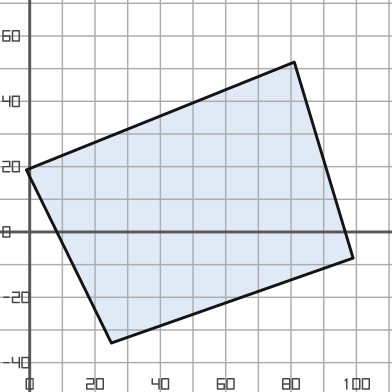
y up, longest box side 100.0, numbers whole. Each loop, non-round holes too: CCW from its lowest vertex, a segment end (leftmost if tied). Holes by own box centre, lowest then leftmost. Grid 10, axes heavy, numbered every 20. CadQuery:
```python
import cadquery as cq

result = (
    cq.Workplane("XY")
    .moveTo(25.0, -34.0)
    .lineTo(99.0, -8.0)
    .lineTo(81.0, 52.0)
    .lineTo(-1.0, 19.0)
    .close()
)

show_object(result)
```